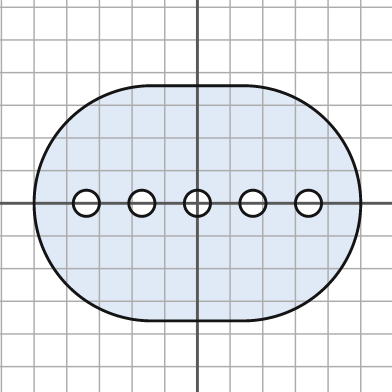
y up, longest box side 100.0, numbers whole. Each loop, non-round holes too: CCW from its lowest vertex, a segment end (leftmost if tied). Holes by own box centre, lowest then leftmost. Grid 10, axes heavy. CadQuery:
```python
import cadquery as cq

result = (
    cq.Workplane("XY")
    .moveTo(-14.0, -36.0)
    .lineTo(14.0, -36.0)
    .threePointArc((50.0, 0.0), (14.0, 36.0))
    .lineTo(-14.0, 36.0)
    .threePointArc((-50.0, 0.0), (-14.0, -36.0))
    .close()
    .moveTo(-34.0, 0.0)
    .circle(4.0)
    .moveTo(-17.0, 0.0)
    .circle(4.0)
    .moveTo(0.0, 0.0)
    .circle(4.0)
    .moveTo(17.0, 0.0)
    .circle(4.0)
    .moveTo(34.0, 0.0)
    .circle(4.0)
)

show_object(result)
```